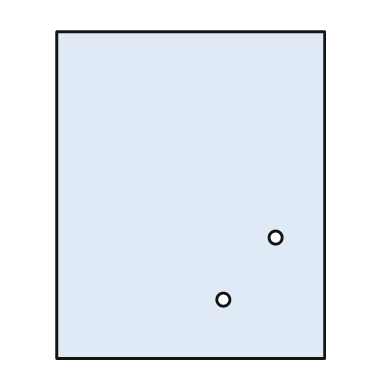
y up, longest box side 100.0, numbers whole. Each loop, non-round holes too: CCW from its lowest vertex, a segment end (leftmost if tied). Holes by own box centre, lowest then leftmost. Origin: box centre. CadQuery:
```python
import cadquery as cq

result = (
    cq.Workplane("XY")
    .moveTo(-41.0, -50.0)
    .lineTo(41.0, -50.0)
    .lineTo(41.0, 50.0)
    .lineTo(-41.0, 50.0)
    .close()
    .moveTo(10.0, -32.0)
    .circle(2.0)
    .moveTo(26.0, -13.0)
    .circle(2.0)
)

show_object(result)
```